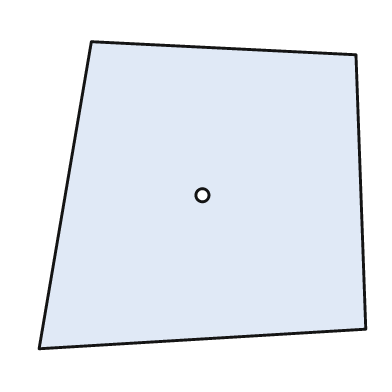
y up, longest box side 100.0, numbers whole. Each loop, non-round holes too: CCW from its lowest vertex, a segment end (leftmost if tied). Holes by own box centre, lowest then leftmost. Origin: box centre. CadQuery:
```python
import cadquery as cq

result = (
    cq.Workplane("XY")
    .moveTo(-50.0, -47.0)
    .lineTo(50.0, -41.0)
    .lineTo(47.0, 43.0)
    .lineTo(-34.0, 47.0)
    .close()
    .moveTo(0.0, 0.0)
    .circle(2.0)
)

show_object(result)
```